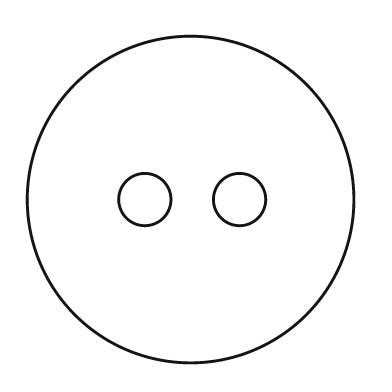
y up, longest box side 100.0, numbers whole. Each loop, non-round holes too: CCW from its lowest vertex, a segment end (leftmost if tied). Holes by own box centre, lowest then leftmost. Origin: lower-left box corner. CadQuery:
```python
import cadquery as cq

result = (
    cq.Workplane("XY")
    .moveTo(50.0, 50.0)
    .circle(50.0)
    .moveTo(36.0, 50.0)
    .circle(8.0)
    .moveTo(65.0, 50.0)
    .circle(8.0)
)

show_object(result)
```